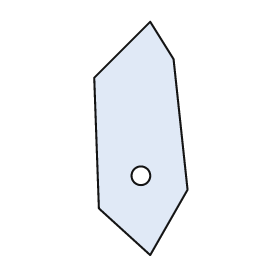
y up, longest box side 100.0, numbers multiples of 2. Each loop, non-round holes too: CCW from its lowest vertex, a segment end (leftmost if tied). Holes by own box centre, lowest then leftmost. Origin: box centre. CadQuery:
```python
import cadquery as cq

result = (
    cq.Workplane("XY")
    .moveTo(4.0, -50.0)
    .lineTo(20.0, -22.0)
    .lineTo(14.0, 34.0)
    .lineTo(4.0, 50.0)
    .lineTo(-20.0, 26.0)
    .lineTo(-18.0, -30.0)
    .close()
    .moveTo(0.0, -16.0)
    .circle(4.0)
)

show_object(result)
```